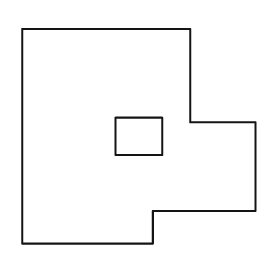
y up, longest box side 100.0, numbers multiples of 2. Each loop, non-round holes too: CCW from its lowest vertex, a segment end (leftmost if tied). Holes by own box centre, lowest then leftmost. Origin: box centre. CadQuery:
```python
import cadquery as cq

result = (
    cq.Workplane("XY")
    .moveTo(-50.0, -46.0)
    .lineTo(6.0, -46.0)
    .lineTo(6.0, -32.0)
    .lineTo(50.0, -32.0)
    .lineTo(50.0, 6.0)
    .lineTo(22.0, 6.0)
    .lineTo(22.0, 46.0)
    .lineTo(-50.0, 46.0)
    .close()
    .moveTo(-10.0, -8.0)
    .lineTo(10.0, -8.0)
    .lineTo(10.0, 8.0)
    .lineTo(-10.0, 8.0)
    .close()
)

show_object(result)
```